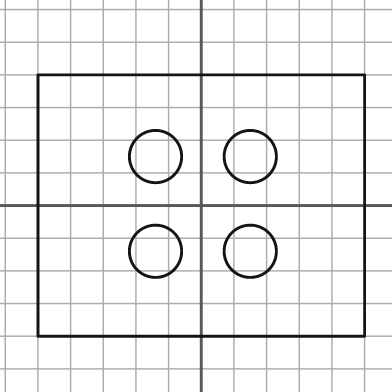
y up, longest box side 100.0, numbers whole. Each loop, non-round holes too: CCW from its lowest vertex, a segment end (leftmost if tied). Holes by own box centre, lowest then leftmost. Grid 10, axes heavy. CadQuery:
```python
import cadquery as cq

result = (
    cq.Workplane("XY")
    .moveTo(-50.0, -40.0)
    .lineTo(50.0, -40.0)
    .lineTo(50.0, 40.0)
    .lineTo(-50.0, 40.0)
    .close()
    .moveTo(-14.0, -14.0)
    .circle(8.0)
    .moveTo(15.0, -14.0)
    .circle(8.0)
    .moveTo(-14.0, 15.0)
    .circle(8.0)
    .moveTo(15.0, 15.0)
    .circle(8.0)
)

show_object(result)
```